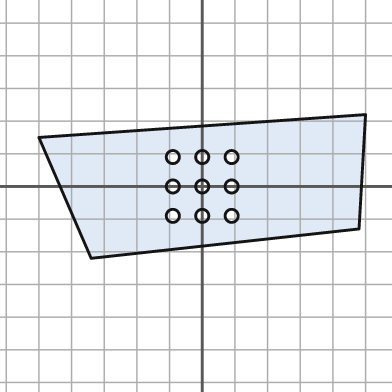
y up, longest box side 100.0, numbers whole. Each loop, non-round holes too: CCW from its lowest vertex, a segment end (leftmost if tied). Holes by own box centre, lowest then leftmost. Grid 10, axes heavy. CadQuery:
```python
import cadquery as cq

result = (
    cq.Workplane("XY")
    .moveTo(-34.0, -22.0)
    .lineTo(48.0, -13.0)
    .lineTo(50.0, 22.0)
    .lineTo(-50.0, 15.0)
    .close()
    .moveTo(-9.0, -9.0)
    .circle(2.0)
    .moveTo(0.0, -9.0)
    .circle(2.0)
    .moveTo(9.0, -9.0)
    .circle(2.0)
    .moveTo(-9.0, 0.0)
    .circle(2.0)
    .moveTo(0.0, 0.0)
    .circle(2.0)
    .moveTo(9.0, 0.0)
    .circle(2.0)
    .moveTo(-9.0, 9.0)
    .circle(2.0)
    .moveTo(0.0, 9.0)
    .circle(2.0)
    .moveTo(9.0, 9.0)
    .circle(2.0)
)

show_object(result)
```